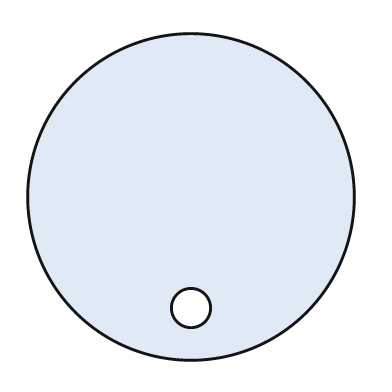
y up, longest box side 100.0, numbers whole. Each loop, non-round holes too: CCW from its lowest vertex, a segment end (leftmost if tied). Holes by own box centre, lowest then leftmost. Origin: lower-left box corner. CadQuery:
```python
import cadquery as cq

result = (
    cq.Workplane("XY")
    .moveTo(50.0, 50.0)
    .circle(50.0)
    .moveTo(50.0, 16.0)
    .circle(6.0)
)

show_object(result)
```